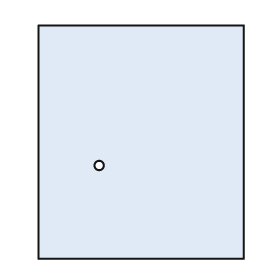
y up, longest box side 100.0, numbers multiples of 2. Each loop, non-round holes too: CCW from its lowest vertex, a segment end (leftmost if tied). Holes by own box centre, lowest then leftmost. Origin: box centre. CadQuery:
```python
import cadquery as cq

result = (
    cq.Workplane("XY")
    .moveTo(-44.0, -50.0)
    .lineTo(44.0, -50.0)
    .lineTo(44.0, 50.0)
    .lineTo(-44.0, 50.0)
    .close()
    .moveTo(-18.0, -10.0)
    .circle(2.0)
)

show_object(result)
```